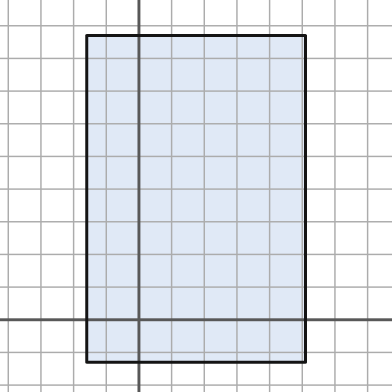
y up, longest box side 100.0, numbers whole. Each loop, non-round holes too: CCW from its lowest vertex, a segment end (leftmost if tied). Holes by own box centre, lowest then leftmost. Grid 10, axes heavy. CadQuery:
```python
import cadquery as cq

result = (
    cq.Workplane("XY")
    .moveTo(-16.0, -13.0)
    .lineTo(51.0, -13.0)
    .lineTo(51.0, 87.0)
    .lineTo(-16.0, 87.0)
    .close()
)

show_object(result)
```